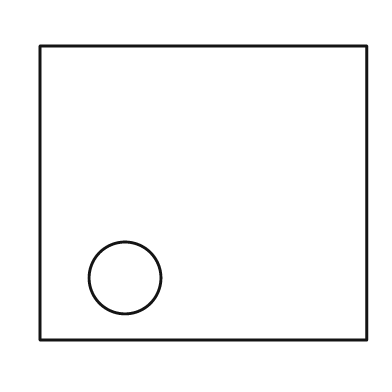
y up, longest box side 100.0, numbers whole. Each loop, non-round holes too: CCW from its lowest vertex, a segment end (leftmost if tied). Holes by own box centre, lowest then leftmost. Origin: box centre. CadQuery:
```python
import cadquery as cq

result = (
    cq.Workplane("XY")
    .moveTo(-50.0, -45.0)
    .lineTo(50.0, -45.0)
    .lineTo(50.0, 45.0)
    .lineTo(-50.0, 45.0)
    .close()
    .moveTo(-24.0, -26.0)
    .circle(11.0)
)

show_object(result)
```